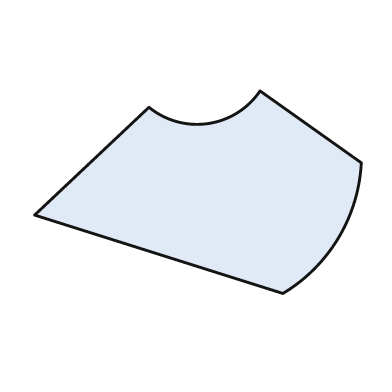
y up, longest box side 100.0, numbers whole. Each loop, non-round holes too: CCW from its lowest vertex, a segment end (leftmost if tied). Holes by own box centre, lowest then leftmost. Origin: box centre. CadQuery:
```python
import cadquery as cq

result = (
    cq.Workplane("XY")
    .moveTo(26.0, -31.0)
    .threePointArc((43.0, -14.0), (50.0, 9.0))
    .lineTo(19.0, 31.0)
    .threePointArc((3.0, 21.0), (-15.0, 26.0))
    .lineTo(-50.0, -7.0)
    .close()
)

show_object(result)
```